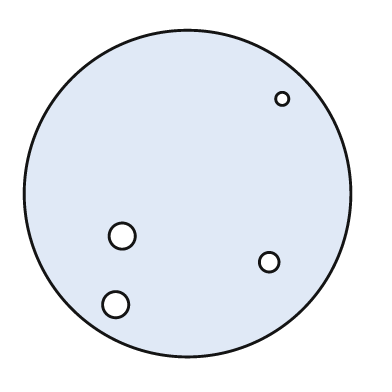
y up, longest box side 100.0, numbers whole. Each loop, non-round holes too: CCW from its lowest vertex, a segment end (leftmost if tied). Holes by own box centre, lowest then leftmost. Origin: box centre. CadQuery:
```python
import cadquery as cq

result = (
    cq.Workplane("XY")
    .moveTo(0.0, 0.0)
    .circle(50.0)
    .moveTo(-22.0, -34.0)
    .circle(4.0)
    .moveTo(25.0, -21.0)
    .circle(3.0)
    .moveTo(-20.0, -13.0)
    .circle(4.0)
    .moveTo(29.0, 29.0)
    .circle(2.0)
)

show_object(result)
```